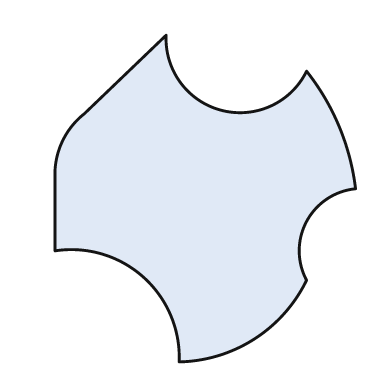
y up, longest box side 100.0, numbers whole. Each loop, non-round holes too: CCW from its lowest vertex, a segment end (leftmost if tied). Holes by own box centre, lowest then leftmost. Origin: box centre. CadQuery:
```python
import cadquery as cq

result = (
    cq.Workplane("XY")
    .moveTo(-8.0, -50.0)
    .threePointArc((15.0, -43.0), (31.0, -25.0))
    .threePointArc((31.0, -7.0), (46.0, 3.0))
    .threePointArc((41.0, 22.0), (31.0, 39.0))
    .threePointArc((5.0, 27.0), (-12.0, 50.0))
    .lineTo(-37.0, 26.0)
    .threePointArc((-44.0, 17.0), (-46.0, 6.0))
    .lineTo(-46.0, -16.0)
    .threePointArc((-19.0, -24.0), (-8.0, -50.0))
    .close()
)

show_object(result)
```